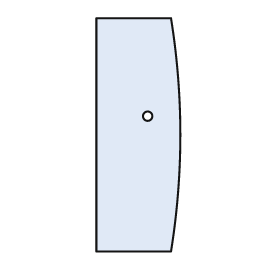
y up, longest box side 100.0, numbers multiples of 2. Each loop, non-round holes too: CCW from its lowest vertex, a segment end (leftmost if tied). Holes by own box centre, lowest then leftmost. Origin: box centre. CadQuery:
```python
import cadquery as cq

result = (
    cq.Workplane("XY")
    .moveTo(-18.0, -50.0)
    .lineTo(14.0, -50.0)
    .threePointArc((18.0, 0.0), (14.0, 50.0))
    .lineTo(-18.0, 50.0)
    .close()
    .moveTo(4.0, 8.0)
    .circle(2.0)
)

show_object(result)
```